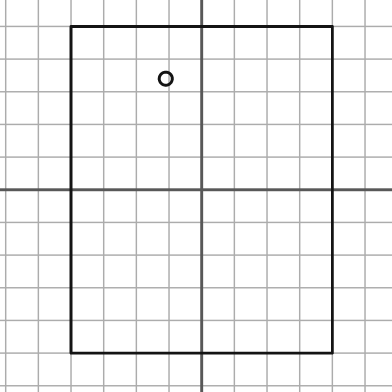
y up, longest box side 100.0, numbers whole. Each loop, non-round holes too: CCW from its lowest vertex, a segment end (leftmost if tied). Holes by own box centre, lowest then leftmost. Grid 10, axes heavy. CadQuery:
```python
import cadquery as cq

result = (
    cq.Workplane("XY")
    .moveTo(-40.0, -50.0)
    .lineTo(40.0, -50.0)
    .lineTo(40.0, 50.0)
    .lineTo(-40.0, 50.0)
    .close()
    .moveTo(-11.0, 34.0)
    .circle(2.0)
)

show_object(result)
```